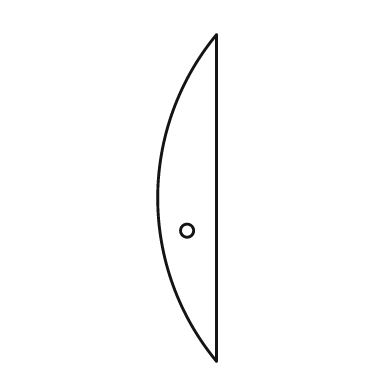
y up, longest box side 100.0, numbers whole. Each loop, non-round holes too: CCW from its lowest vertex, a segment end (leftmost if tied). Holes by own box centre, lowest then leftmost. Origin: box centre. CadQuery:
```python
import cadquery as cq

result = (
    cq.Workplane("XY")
    .moveTo(9.0, -50.0)
    .lineTo(9.0, 50.0)
    .threePointArc((-9.0, 0.0), (9.0, -50.0))
    .close()
    .moveTo(0.0, -10.0)
    .circle(2.0)
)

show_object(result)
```